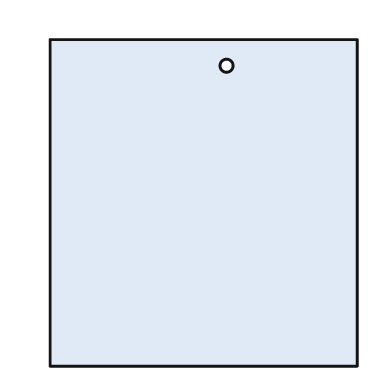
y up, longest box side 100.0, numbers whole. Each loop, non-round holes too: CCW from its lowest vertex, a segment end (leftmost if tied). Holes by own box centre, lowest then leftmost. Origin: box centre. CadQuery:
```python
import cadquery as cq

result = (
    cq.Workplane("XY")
    .moveTo(-47.0, -50.0)
    .lineTo(47.0, -50.0)
    .lineTo(47.0, 50.0)
    .lineTo(-47.0, 50.0)
    .close()
    .moveTo(7.0, 42.0)
    .circle(2.0)
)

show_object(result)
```